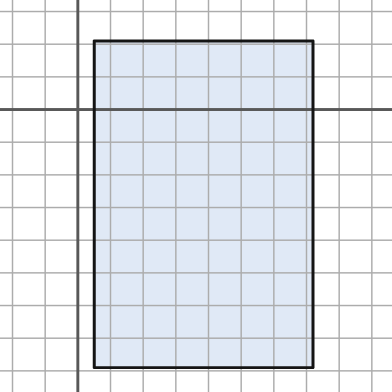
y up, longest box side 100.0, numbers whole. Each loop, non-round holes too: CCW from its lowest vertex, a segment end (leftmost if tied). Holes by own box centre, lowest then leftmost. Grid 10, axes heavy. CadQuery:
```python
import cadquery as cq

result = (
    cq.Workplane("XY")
    .moveTo(5.0, -79.0)
    .lineTo(72.0, -79.0)
    .lineTo(72.0, 21.0)
    .lineTo(5.0, 21.0)
    .close()
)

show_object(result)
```